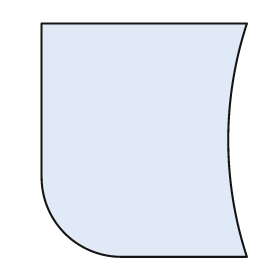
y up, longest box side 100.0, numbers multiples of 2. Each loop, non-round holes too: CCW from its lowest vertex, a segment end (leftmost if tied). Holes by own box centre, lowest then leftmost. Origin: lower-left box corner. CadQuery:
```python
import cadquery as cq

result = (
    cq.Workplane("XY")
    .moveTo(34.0, 0.0)
    .lineTo(88.0, 0.0)
    .threePointArc((80.0, 50.0), (88.0, 100.0))
    .lineTo(0.0, 100.0)
    .lineTo(0.0, 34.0)
    .threePointArc((10.0, 10.0), (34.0, 0.0))
    .close()
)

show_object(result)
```